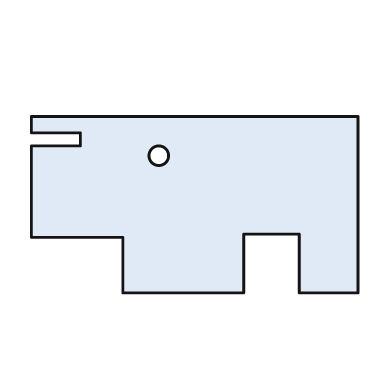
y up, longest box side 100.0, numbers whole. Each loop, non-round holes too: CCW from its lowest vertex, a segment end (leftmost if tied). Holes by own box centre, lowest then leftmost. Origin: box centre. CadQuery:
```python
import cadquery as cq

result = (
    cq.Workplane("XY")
    .moveTo(-22.0, -27.0)
    .lineTo(15.0, -27.0)
    .lineTo(15.0, -9.0)
    .lineTo(32.0, -9.0)
    .lineTo(32.0, -27.0)
    .lineTo(50.0, -27.0)
    .lineTo(50.0, 27.0)
    .lineTo(-50.0, 27.0)
    .lineTo(-50.0, 22.0)
    .lineTo(-35.0, 22.0)
    .lineTo(-35.0, 18.0)
    .lineTo(-50.0, 18.0)
    .lineTo(-50.0, -10.0)
    .lineTo(-22.0, -10.0)
    .close()
    .moveTo(-11.0, 15.0)
    .circle(3.0)
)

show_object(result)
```